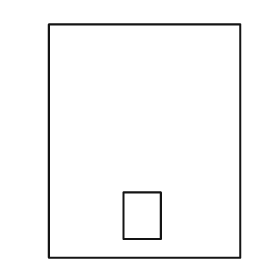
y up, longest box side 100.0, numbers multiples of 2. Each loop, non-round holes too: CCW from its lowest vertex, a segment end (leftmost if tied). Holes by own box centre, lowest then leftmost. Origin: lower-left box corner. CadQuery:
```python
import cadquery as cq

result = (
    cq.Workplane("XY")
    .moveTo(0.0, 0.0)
    .lineTo(82.0, 0.0)
    .lineTo(82.0, 100.0)
    .lineTo(0.0, 100.0)
    .close()
    .moveTo(32.0, 8.0)
    .lineTo(48.0, 8.0)
    .lineTo(48.0, 28.0)
    .lineTo(32.0, 28.0)
    .close()
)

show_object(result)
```